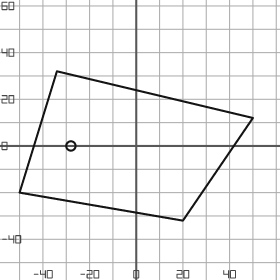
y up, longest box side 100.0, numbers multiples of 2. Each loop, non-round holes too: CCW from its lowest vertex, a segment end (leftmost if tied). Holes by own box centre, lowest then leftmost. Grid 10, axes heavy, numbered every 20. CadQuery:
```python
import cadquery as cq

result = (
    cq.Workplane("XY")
    .moveTo(20.0, -32.0)
    .lineTo(50.0, 12.0)
    .lineTo(-34.0, 32.0)
    .lineTo(-50.0, -20.0)
    .close()
    .moveTo(-28.0, 0.0)
    .circle(2.0)
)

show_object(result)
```